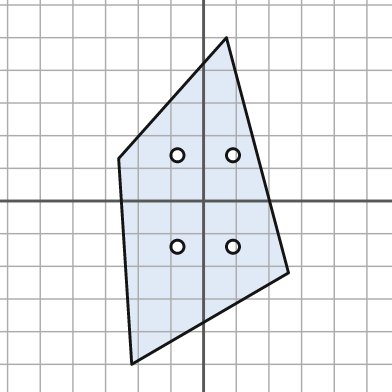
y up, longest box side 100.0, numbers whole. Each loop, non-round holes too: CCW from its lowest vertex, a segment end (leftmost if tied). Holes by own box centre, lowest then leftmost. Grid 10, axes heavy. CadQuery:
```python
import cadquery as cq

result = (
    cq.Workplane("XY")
    .moveTo(-22.0, -50.0)
    .lineTo(26.0, -22.0)
    .lineTo(7.0, 50.0)
    .lineTo(-26.0, 13.0)
    .close()
    .moveTo(-8.0, -14.0)
    .circle(2.0)
    .moveTo(9.0, -14.0)
    .circle(2.0)
    .moveTo(-8.0, 14.0)
    .circle(2.0)
    .moveTo(9.0, 14.0)
    .circle(2.0)
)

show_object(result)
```